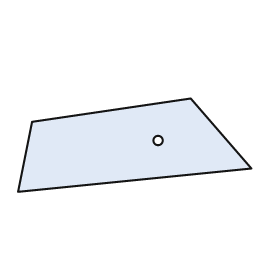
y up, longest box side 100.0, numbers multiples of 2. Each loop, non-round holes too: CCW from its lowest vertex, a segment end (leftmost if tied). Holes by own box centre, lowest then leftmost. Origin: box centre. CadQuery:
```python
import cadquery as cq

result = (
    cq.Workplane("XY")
    .moveTo(-50.0, -20.0)
    .lineTo(50.0, -10.0)
    .lineTo(24.0, 20.0)
    .lineTo(-44.0, 10.0)
    .close()
    .moveTo(10.0, 2.0)
    .circle(2.0)
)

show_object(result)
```